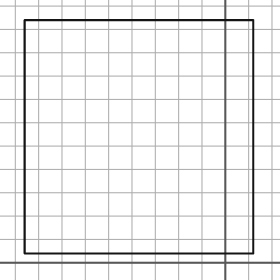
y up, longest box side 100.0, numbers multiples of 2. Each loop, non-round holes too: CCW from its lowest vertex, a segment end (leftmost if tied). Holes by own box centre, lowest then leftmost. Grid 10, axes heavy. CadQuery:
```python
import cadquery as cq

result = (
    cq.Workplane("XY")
    .moveTo(-86.0, 4.0)
    .lineTo(12.0, 4.0)
    .lineTo(12.0, 104.0)
    .lineTo(-86.0, 104.0)
    .close()
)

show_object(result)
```